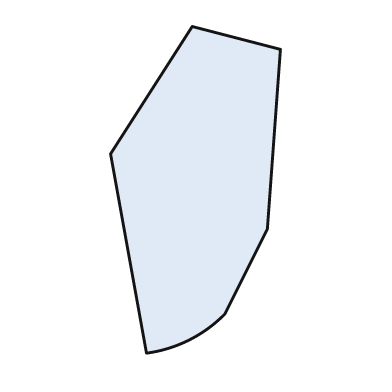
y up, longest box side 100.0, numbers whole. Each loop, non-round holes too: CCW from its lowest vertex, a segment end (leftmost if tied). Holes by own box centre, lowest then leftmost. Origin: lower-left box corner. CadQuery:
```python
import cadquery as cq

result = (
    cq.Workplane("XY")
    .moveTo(11.0, 0.0)
    .threePointArc((24.0, 4.0), (35.0, 12.0))
    .lineTo(48.0, 38.0)
    .lineTo(52.0, 93.0)
    .lineTo(25.0, 100.0)
    .lineTo(0.0, 61.0)
    .close()
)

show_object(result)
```